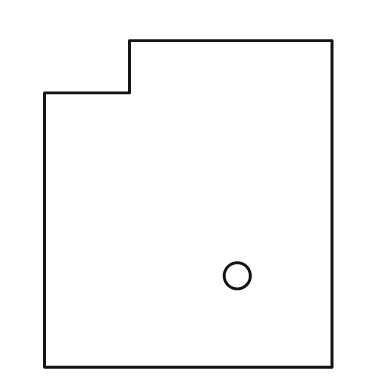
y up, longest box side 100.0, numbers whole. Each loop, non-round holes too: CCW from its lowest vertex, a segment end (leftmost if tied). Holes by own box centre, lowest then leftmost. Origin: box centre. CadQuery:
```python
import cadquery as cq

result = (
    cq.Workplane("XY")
    .moveTo(-44.0, -50.0)
    .lineTo(44.0, -50.0)
    .lineTo(44.0, 50.0)
    .lineTo(-18.0, 50.0)
    .lineTo(-18.0, 34.0)
    .lineTo(-44.0, 34.0)
    .close()
    .moveTo(15.0, -22.0)
    .circle(4.0)
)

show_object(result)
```